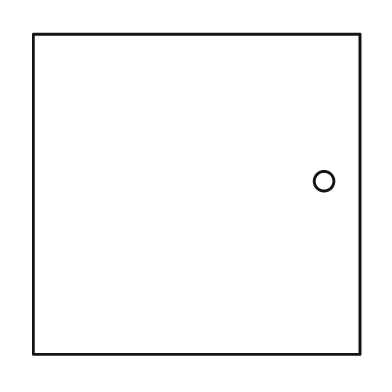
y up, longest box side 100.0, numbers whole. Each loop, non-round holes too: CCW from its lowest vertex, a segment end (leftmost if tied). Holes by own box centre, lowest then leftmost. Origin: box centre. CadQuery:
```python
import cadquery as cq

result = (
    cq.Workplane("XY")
    .moveTo(-50.0, -49.0)
    .lineTo(50.0, -49.0)
    .lineTo(50.0, 49.0)
    .lineTo(-50.0, 49.0)
    .close()
    .moveTo(39.0, 4.0)
    .circle(3.0)
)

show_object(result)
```